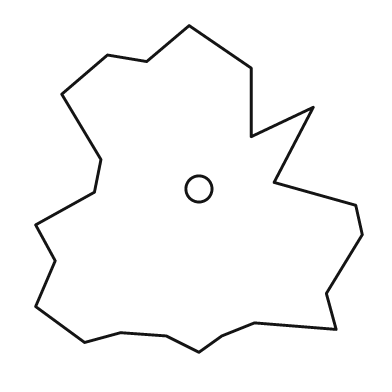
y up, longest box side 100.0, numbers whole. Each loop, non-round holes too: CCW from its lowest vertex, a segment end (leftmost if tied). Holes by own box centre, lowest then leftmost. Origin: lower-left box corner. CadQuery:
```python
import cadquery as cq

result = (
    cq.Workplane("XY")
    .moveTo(50.0, 0.0)
    .lineTo(57.0, 5.0)
    .lineTo(67.0, 9.0)
    .lineTo(92.0, 7.0)
    .lineTo(89.0, 18.0)
    .lineTo(100.0, 36.0)
    .lineTo(98.0, 45.0)
    .lineTo(73.0, 52.0)
    .lineTo(85.0, 75.0)
    .lineTo(66.0, 66.0)
    .lineTo(66.0, 87.0)
    .lineTo(47.0, 100.0)
    .lineTo(34.0, 89.0)
    .lineTo(22.0, 91.0)
    .lineTo(8.0, 79.0)
    .lineTo(20.0, 59.0)
    .lineTo(18.0, 49.0)
    .lineTo(0.0, 39.0)
    .lineTo(6.0, 28.0)
    .lineTo(0.0, 14.0)
    .lineTo(15.0, 3.0)
    .lineTo(26.0, 6.0)
    .lineTo(40.0, 5.0)
    .close()
    .moveTo(50.0, 50.0)
    .circle(4.0)
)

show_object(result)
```